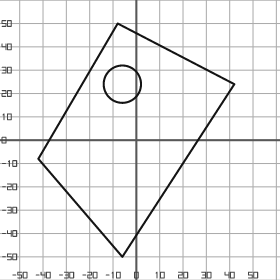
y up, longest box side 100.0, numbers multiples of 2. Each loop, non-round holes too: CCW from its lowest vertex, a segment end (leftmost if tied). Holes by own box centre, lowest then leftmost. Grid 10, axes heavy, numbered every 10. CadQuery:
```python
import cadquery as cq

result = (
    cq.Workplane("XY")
    .moveTo(-6.0, -50.0)
    .lineTo(42.0, 24.0)
    .lineTo(-8.0, 50.0)
    .lineTo(-42.0, -8.0)
    .close()
    .moveTo(-6.0, 24.0)
    .circle(8.0)
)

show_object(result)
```